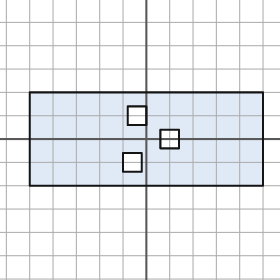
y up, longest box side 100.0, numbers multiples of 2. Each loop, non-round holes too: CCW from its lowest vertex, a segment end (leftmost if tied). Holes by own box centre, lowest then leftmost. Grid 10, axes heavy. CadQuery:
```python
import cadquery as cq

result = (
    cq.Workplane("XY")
    .moveTo(-50.0, -20.0)
    .lineTo(50.0, -20.0)
    .lineTo(50.0, 20.0)
    .lineTo(-50.0, 20.0)
    .close()
    .moveTo(-10.0, -14.0)
    .lineTo(-2.0, -14.0)
    .lineTo(-2.0, -6.0)
    .lineTo(-10.0, -6.0)
    .close()
    .moveTo(6.0, -4.0)
    .lineTo(14.0, -4.0)
    .lineTo(14.0, 4.0)
    .lineTo(6.0, 4.0)
    .close()
    .moveTo(-8.0, 6.0)
    .lineTo(0.0, 6.0)
    .lineTo(0.0, 14.0)
    .lineTo(-8.0, 14.0)
    .close()
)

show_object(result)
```